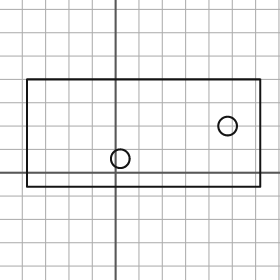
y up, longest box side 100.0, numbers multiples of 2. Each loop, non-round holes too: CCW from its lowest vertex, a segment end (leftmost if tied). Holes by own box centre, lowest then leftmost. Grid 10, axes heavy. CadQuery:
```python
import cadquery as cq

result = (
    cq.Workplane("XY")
    .moveTo(-38.0, -6.0)
    .lineTo(62.0, -6.0)
    .lineTo(62.0, 40.0)
    .lineTo(-38.0, 40.0)
    .close()
    .moveTo(2.0, 6.0)
    .circle(4.0)
    .moveTo(48.0, 20.0)
    .circle(4.0)
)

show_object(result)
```